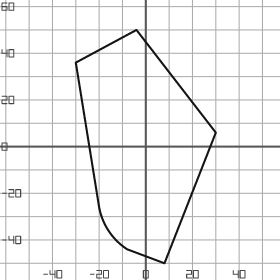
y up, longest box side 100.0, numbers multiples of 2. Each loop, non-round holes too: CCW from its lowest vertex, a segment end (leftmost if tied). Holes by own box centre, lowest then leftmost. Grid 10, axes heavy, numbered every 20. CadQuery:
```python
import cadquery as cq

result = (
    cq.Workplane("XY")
    .moveTo(8.0, -50.0)
    .lineTo(30.0, 6.0)
    .lineTo(-4.0, 50.0)
    .lineTo(-30.0, 36.0)
    .lineTo(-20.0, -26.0)
    .threePointArc((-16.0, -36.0), (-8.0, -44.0))
    .close()
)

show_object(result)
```